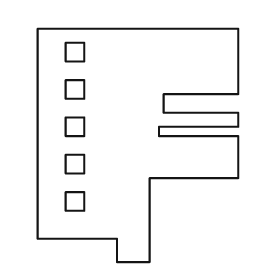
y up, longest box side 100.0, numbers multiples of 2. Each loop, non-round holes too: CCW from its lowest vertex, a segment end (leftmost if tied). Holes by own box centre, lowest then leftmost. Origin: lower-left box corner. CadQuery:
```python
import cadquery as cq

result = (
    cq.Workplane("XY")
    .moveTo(34.0, 0.0)
    .lineTo(48.0, 0.0)
    .lineTo(48.0, 36.0)
    .lineTo(86.0, 36.0)
    .lineTo(86.0, 54.0)
    .lineTo(52.0, 54.0)
    .lineTo(52.0, 58.0)
    .lineTo(86.0, 58.0)
    .lineTo(86.0, 64.0)
    .lineTo(54.0, 64.0)
    .lineTo(54.0, 72.0)
    .lineTo(86.0, 72.0)
    .lineTo(86.0, 100.0)
    .lineTo(0.0, 100.0)
    .lineTo(0.0, 10.0)
    .lineTo(34.0, 10.0)
    .close()
    .moveTo(12.0, 22.0)
    .lineTo(20.0, 22.0)
    .lineTo(20.0, 30.0)
    .lineTo(12.0, 30.0)
    .close()
    .moveTo(12.0, 38.0)
    .lineTo(20.0, 38.0)
    .lineTo(20.0, 46.0)
    .lineTo(12.0, 46.0)
    .close()
    .moveTo(12.0, 54.0)
    .lineTo(20.0, 54.0)
    .lineTo(20.0, 62.0)
    .lineTo(12.0, 62.0)
    .close()
    .moveTo(12.0, 70.0)
    .lineTo(20.0, 70.0)
    .lineTo(20.0, 78.0)
    .lineTo(12.0, 78.0)
    .close()
    .moveTo(12.0, 86.0)
    .lineTo(20.0, 86.0)
    .lineTo(20.0, 94.0)
    .lineTo(12.0, 94.0)
    .close()
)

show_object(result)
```